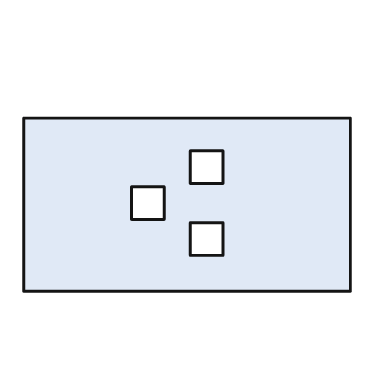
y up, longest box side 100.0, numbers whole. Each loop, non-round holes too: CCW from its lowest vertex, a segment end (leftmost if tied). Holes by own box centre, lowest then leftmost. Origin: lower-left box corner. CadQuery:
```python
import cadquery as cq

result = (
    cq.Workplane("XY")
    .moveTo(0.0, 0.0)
    .lineTo(100.0, 0.0)
    .lineTo(100.0, 53.0)
    .lineTo(0.0, 53.0)
    .close()
    .moveTo(51.0, 11.0)
    .lineTo(61.0, 11.0)
    .lineTo(61.0, 21.0)
    .lineTo(51.0, 21.0)
    .close()
    .moveTo(33.0, 22.0)
    .lineTo(43.0, 22.0)
    .lineTo(43.0, 32.0)
    .lineTo(33.0, 32.0)
    .close()
    .moveTo(51.0, 33.0)
    .lineTo(61.0, 33.0)
    .lineTo(61.0, 43.0)
    .lineTo(51.0, 43.0)
    .close()
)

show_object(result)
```